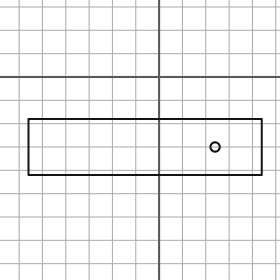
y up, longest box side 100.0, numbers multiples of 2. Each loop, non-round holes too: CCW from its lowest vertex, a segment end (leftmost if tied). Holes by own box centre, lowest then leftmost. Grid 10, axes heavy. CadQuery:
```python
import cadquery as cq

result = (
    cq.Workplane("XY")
    .moveTo(-56.0, -42.0)
    .lineTo(44.0, -42.0)
    .lineTo(44.0, -18.0)
    .lineTo(-56.0, -18.0)
    .close()
    .moveTo(24.0, -30.0)
    .circle(2.0)
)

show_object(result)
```